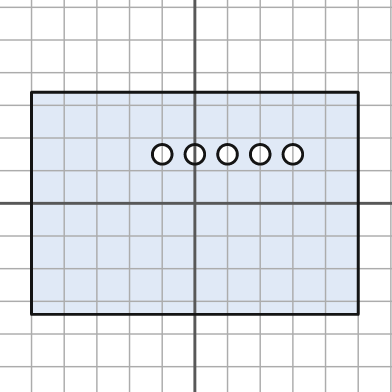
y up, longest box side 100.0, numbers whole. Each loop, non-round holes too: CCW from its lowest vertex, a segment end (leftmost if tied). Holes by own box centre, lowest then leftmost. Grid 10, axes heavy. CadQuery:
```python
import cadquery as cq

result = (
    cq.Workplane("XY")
    .moveTo(-50.0, -34.0)
    .lineTo(50.0, -34.0)
    .lineTo(50.0, 34.0)
    .lineTo(-50.0, 34.0)
    .close()
    .moveTo(-10.0, 15.0)
    .circle(3.0)
    .moveTo(0.0, 15.0)
    .circle(3.0)
    .moveTo(10.0, 15.0)
    .circle(3.0)
    .moveTo(20.0, 15.0)
    .circle(3.0)
    .moveTo(30.0, 15.0)
    .circle(3.0)
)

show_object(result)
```